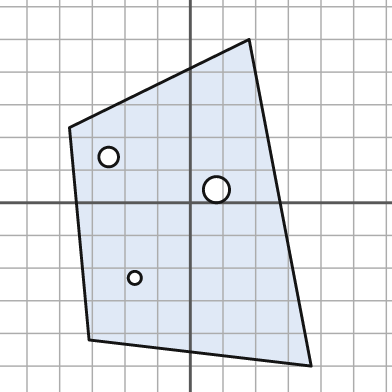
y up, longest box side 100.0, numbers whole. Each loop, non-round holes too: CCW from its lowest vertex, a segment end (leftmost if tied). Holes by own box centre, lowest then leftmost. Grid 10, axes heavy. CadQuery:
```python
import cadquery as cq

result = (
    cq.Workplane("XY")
    .moveTo(37.0, -50.0)
    .lineTo(18.0, 50.0)
    .lineTo(-37.0, 23.0)
    .lineTo(-31.0, -42.0)
    .close()
    .moveTo(-17.0, -23.0)
    .circle(2.0)
    .moveTo(8.0, 4.0)
    .circle(4.0)
    .moveTo(-25.0, 14.0)
    .circle(3.0)
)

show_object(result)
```